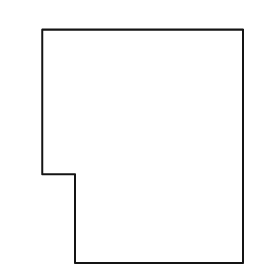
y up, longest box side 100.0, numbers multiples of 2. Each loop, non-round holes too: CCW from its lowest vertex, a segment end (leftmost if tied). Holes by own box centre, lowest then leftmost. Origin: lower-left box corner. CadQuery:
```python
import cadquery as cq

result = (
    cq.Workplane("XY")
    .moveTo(14.0, 0.0)
    .lineTo(86.0, 0.0)
    .lineTo(86.0, 100.0)
    .lineTo(0.0, 100.0)
    .lineTo(0.0, 38.0)
    .lineTo(14.0, 38.0)
    .close()
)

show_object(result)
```